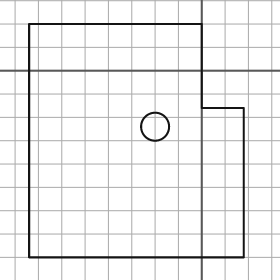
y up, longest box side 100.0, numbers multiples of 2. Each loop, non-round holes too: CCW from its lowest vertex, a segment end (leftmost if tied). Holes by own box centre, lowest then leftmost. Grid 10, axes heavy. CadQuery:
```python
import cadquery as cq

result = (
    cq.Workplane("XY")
    .moveTo(-74.0, -80.0)
    .lineTo(18.0, -80.0)
    .lineTo(18.0, -16.0)
    .lineTo(0.0, -16.0)
    .lineTo(0.0, 20.0)
    .lineTo(-74.0, 20.0)
    .close()
    .moveTo(-20.0, -24.0)
    .circle(6.0)
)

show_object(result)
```